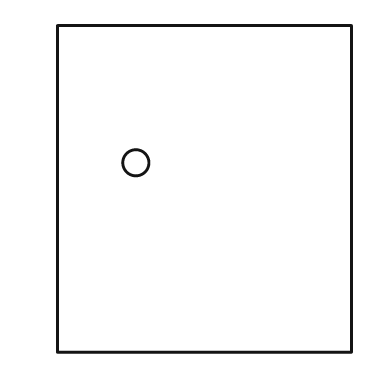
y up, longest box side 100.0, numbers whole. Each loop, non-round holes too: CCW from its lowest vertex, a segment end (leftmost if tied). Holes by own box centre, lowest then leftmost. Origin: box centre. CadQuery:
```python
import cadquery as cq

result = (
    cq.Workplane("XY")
    .moveTo(-45.0, -50.0)
    .lineTo(45.0, -50.0)
    .lineTo(45.0, 50.0)
    .lineTo(-45.0, 50.0)
    .close()
    .moveTo(-21.0, 8.0)
    .circle(4.0)
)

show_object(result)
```